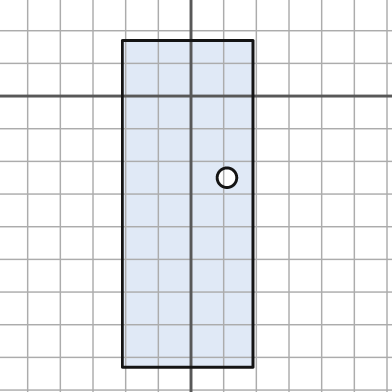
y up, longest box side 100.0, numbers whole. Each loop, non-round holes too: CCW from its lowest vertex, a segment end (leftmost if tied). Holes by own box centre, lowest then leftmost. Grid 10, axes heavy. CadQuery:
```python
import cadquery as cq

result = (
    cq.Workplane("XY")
    .moveTo(-21.0, -83.0)
    .lineTo(19.0, -83.0)
    .lineTo(19.0, 17.0)
    .lineTo(-21.0, 17.0)
    .close()
    .moveTo(11.0, -25.0)
    .circle(3.0)
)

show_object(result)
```